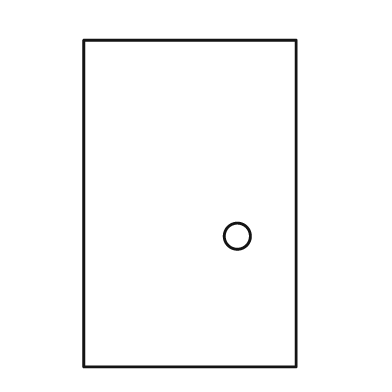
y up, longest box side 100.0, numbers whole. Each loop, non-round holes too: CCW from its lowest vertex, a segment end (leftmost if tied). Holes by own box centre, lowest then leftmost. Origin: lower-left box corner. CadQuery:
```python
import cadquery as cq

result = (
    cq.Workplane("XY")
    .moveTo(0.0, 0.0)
    .lineTo(65.0, 0.0)
    .lineTo(65.0, 100.0)
    .lineTo(0.0, 100.0)
    .close()
    .moveTo(47.0, 40.0)
    .circle(4.0)
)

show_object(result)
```